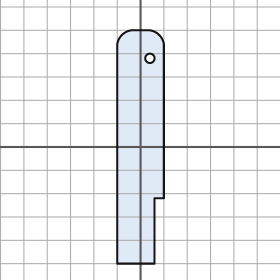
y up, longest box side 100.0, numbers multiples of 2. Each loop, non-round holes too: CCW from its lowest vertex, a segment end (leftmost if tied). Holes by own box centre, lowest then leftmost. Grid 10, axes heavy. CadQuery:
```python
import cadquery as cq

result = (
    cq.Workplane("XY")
    .moveTo(-10.0, -50.0)
    .lineTo(6.0, -50.0)
    .lineTo(6.0, -22.0)
    .lineTo(10.0, -22.0)
    .lineTo(10.0, 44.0)
    .threePointArc((8.0, 48.0), (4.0, 50.0))
    .lineTo(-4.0, 50.0)
    .threePointArc((-8.0, 48.0), (-10.0, 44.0))
    .close()
    .moveTo(4.0, 38.0)
    .circle(2.0)
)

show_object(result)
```